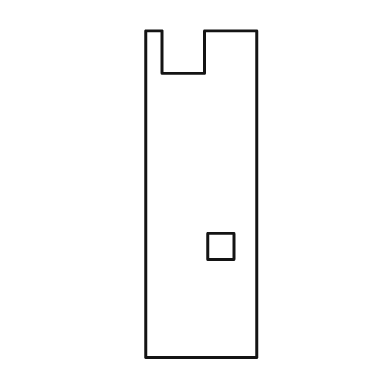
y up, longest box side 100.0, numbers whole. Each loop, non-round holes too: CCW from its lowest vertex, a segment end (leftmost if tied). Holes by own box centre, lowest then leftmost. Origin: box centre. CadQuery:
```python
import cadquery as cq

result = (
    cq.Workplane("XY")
    .moveTo(-17.0, -50.0)
    .lineTo(17.0, -50.0)
    .lineTo(17.0, 50.0)
    .lineTo(1.0, 50.0)
    .lineTo(1.0, 37.0)
    .lineTo(-12.0, 37.0)
    .lineTo(-12.0, 50.0)
    .lineTo(-17.0, 50.0)
    .close()
    .moveTo(2.0, -20.0)
    .lineTo(10.0, -20.0)
    .lineTo(10.0, -12.0)
    .lineTo(2.0, -12.0)
    .close()
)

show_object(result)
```